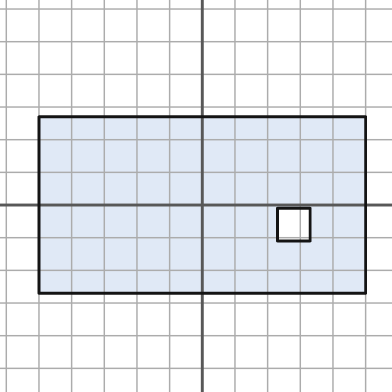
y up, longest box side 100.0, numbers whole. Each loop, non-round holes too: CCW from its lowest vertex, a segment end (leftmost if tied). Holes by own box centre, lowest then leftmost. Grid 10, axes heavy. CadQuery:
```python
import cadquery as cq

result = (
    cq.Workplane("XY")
    .moveTo(-50.0, -27.0)
    .lineTo(50.0, -27.0)
    .lineTo(50.0, 27.0)
    .lineTo(-50.0, 27.0)
    .close()
    .moveTo(23.0, -11.0)
    .lineTo(33.0, -11.0)
    .lineTo(33.0, -1.0)
    .lineTo(23.0, -1.0)
    .close()
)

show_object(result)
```